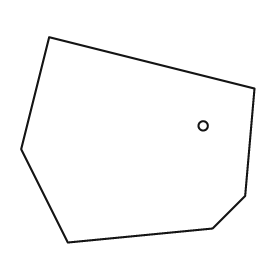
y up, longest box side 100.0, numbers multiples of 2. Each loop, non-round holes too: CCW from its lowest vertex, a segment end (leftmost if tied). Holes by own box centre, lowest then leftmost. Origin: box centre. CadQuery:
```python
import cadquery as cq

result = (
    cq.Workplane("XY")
    .moveTo(-30.0, -44.0)
    .lineTo(32.0, -38.0)
    .lineTo(46.0, -24.0)
    .lineTo(50.0, 22.0)
    .lineTo(-38.0, 44.0)
    .lineTo(-50.0, -4.0)
    .close()
    .moveTo(28.0, 6.0)
    .circle(2.0)
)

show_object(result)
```